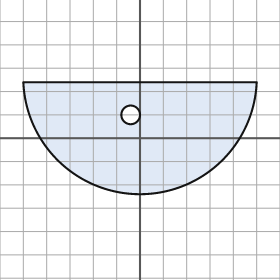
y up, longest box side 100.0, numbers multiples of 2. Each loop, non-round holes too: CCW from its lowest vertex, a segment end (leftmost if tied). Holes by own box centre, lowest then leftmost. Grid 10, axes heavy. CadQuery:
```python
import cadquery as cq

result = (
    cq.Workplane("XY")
    .moveTo(-50.0, 24.0)
    .threePointArc((0.0, -24.0), (50.0, 24.0))
    .close()
    .moveTo(-4.0, 10.0)
    .circle(4.0)
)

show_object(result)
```